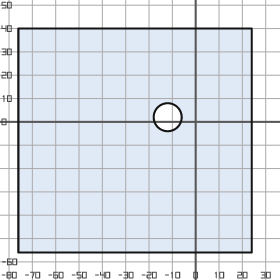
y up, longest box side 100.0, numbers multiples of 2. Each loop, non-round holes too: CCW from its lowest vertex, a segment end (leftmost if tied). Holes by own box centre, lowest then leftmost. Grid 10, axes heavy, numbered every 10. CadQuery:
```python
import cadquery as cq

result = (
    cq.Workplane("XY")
    .moveTo(-76.0, -56.0)
    .lineTo(24.0, -56.0)
    .lineTo(24.0, 40.0)
    .lineTo(-76.0, 40.0)
    .close()
    .moveTo(-12.0, 2.0)
    .circle(6.0)
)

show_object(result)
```